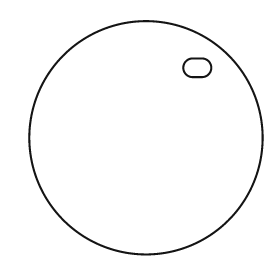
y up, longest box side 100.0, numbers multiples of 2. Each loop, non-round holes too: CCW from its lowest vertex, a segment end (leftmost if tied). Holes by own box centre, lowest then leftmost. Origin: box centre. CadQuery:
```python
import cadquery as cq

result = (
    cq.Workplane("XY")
    .moveTo(0.0, 0.0)
    .circle(50.0)
    .moveTo(20.0, 26.0)
    .lineTo(24.0, 26.0)
    .threePointArc((28.0, 30.0), (24.0, 34.0))
    .lineTo(20.0, 34.0)
    .threePointArc((16.0, 30.0), (20.0, 26.0))
    .close()
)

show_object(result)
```